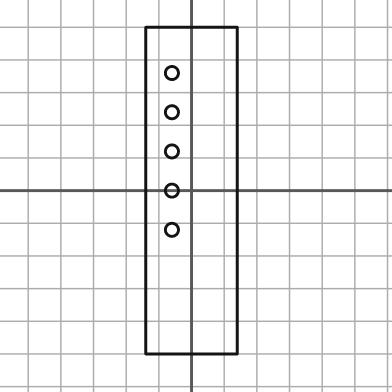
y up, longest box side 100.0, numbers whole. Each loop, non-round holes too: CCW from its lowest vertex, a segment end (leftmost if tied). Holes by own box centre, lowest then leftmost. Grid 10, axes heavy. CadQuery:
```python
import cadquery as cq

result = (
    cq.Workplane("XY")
    .moveTo(-14.0, -50.0)
    .lineTo(14.0, -50.0)
    .lineTo(14.0, 50.0)
    .lineTo(-14.0, 50.0)
    .close()
    .moveTo(-6.0, -12.0)
    .circle(2.0)
    .moveTo(-6.0, 0.0)
    .circle(2.0)
    .moveTo(-6.0, 12.0)
    .circle(2.0)
    .moveTo(-6.0, 24.0)
    .circle(2.0)
    .moveTo(-6.0, 36.0)
    .circle(2.0)
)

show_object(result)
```